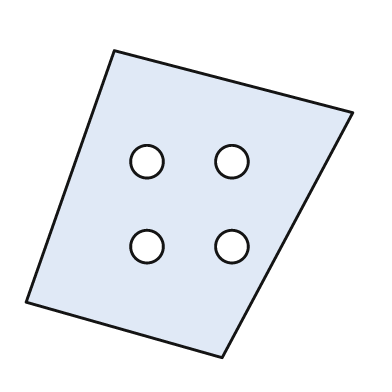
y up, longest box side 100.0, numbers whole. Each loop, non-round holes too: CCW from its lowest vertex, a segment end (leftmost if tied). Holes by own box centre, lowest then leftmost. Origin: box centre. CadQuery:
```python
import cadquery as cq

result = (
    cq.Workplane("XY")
    .moveTo(10.0, -47.0)
    .lineTo(50.0, 28.0)
    .lineTo(-23.0, 47.0)
    .lineTo(-50.0, -30.0)
    .close()
    .moveTo(-13.0, -13.0)
    .circle(5.0)
    .moveTo(13.0, -13.0)
    .circle(5.0)
    .moveTo(-13.0, 13.0)
    .circle(5.0)
    .moveTo(13.0, 13.0)
    .circle(5.0)
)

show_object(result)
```